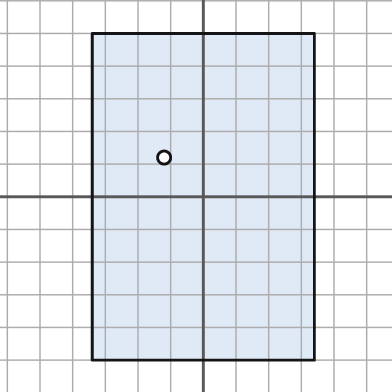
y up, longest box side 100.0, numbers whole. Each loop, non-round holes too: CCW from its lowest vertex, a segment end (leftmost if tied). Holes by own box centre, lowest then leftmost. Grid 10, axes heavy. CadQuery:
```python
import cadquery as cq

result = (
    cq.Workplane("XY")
    .moveTo(-34.0, -50.0)
    .lineTo(34.0, -50.0)
    .lineTo(34.0, 50.0)
    .lineTo(-34.0, 50.0)
    .close()
    .moveTo(-12.0, 12.0)
    .circle(2.0)
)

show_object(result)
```